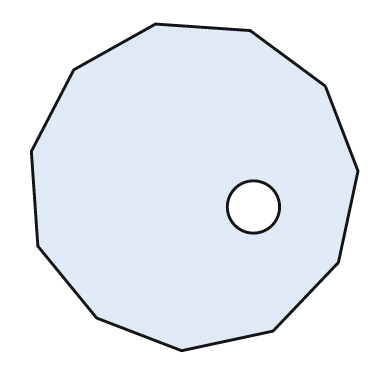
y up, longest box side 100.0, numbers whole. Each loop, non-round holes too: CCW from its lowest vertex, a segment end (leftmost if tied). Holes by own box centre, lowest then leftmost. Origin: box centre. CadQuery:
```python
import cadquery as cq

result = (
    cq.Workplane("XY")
    .moveTo(-4.0, -50.0)
    .lineTo(24.0, -44.0)
    .lineTo(44.0, -23.0)
    .lineTo(50.0, 5.0)
    .lineTo(40.0, 31.0)
    .lineTo(17.0, 48.0)
    .lineTo(-12.0, 50.0)
    .lineTo(-37.0, 36.0)
    .lineTo(-50.0, 11.0)
    .lineTo(-48.0, -18.0)
    .lineTo(-30.0, -40.0)
    .close()
    .moveTo(18.0, -6.0)
    .circle(8.0)
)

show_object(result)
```